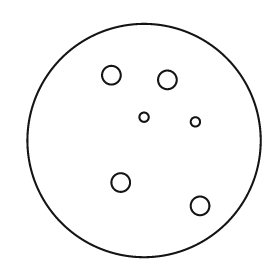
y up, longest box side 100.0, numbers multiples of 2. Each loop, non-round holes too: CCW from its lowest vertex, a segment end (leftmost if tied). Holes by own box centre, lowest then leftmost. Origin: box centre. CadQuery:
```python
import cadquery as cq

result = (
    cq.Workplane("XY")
    .moveTo(0.0, 0.0)
    .circle(50.0)
    .moveTo(24.0, -28.0)
    .circle(4.0)
    .moveTo(-10.0, -18.0)
    .circle(4.0)
    .moveTo(22.0, 8.0)
    .circle(2.0)
    .moveTo(0.0, 10.0)
    .circle(2.0)
    .moveTo(10.0, 26.0)
    .circle(4.0)
    .moveTo(-14.0, 28.0)
    .circle(4.0)
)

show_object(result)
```